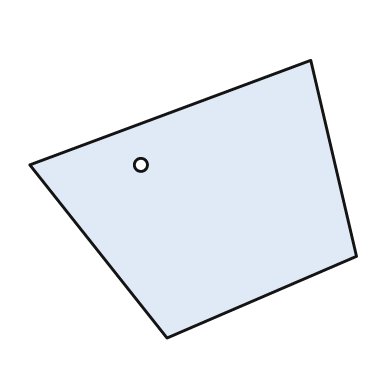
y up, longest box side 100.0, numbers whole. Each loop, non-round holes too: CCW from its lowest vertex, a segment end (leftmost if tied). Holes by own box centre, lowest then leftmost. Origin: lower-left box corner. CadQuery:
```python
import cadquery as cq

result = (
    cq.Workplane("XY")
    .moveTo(42.0, 0.0)
    .lineTo(100.0, 25.0)
    .lineTo(86.0, 85.0)
    .lineTo(0.0, 53.0)
    .close()
    .moveTo(34.0, 53.0)
    .circle(2.0)
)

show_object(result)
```